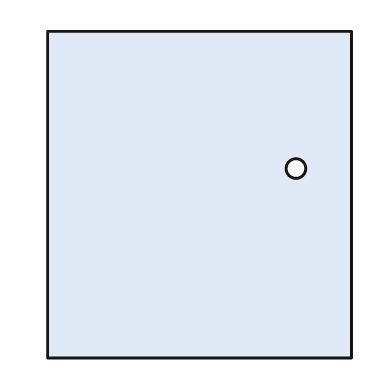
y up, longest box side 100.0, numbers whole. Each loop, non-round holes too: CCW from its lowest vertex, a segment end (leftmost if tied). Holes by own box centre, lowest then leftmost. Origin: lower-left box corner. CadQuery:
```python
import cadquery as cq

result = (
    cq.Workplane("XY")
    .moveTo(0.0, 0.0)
    .lineTo(93.0, 0.0)
    .lineTo(93.0, 100.0)
    .lineTo(0.0, 100.0)
    .close()
    .moveTo(76.0, 58.0)
    .circle(3.0)
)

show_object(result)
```